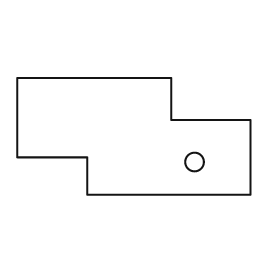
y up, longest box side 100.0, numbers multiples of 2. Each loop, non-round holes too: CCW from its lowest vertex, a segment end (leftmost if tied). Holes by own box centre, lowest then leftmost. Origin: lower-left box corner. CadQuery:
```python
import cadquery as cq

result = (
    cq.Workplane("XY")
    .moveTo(30.0, 0.0)
    .lineTo(100.0, 0.0)
    .lineTo(100.0, 32.0)
    .lineTo(66.0, 32.0)
    .lineTo(66.0, 50.0)
    .lineTo(0.0, 50.0)
    .lineTo(0.0, 16.0)
    .lineTo(30.0, 16.0)
    .close()
    .moveTo(76.0, 14.0)
    .circle(4.0)
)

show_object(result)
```